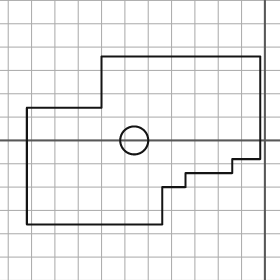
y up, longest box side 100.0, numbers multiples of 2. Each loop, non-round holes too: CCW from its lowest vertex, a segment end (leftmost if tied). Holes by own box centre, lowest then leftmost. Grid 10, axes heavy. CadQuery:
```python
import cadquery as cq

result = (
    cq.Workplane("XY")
    .moveTo(-102.0, -36.0)
    .lineTo(-44.0, -36.0)
    .lineTo(-44.0, -20.0)
    .lineTo(-34.0, -20.0)
    .lineTo(-34.0, -14.0)
    .lineTo(-14.0, -14.0)
    .lineTo(-14.0, -8.0)
    .lineTo(-2.0, -8.0)
    .lineTo(-2.0, 36.0)
    .lineTo(-70.0, 36.0)
    .lineTo(-70.0, 14.0)
    .lineTo(-102.0, 14.0)
    .close()
    .moveTo(-56.0, 0.0)
    .circle(6.0)
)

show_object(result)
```